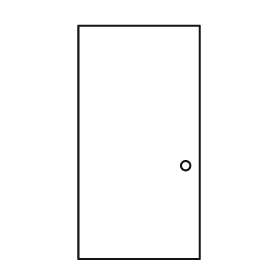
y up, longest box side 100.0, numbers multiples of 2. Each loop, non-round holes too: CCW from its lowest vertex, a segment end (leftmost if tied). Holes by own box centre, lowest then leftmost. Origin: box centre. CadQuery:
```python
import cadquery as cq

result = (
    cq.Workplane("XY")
    .moveTo(-26.0, -50.0)
    .lineTo(26.0, -50.0)
    .lineTo(26.0, 50.0)
    .lineTo(-26.0, 50.0)
    .close()
    .moveTo(20.0, -10.0)
    .circle(2.0)
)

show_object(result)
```